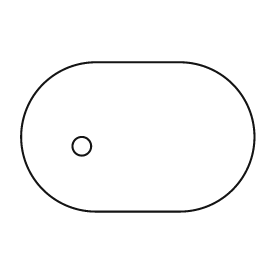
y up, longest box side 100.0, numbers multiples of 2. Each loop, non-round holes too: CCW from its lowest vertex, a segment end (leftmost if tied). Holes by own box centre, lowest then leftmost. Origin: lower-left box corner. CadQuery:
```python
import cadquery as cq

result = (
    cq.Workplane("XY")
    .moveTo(32.0, 0.0)
    .lineTo(68.0, 0.0)
    .threePointArc((100.0, 32.0), (68.0, 64.0))
    .lineTo(32.0, 64.0)
    .threePointArc((0.0, 32.0), (32.0, 0.0))
    .close()
    .moveTo(26.0, 28.0)
    .circle(4.0)
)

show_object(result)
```